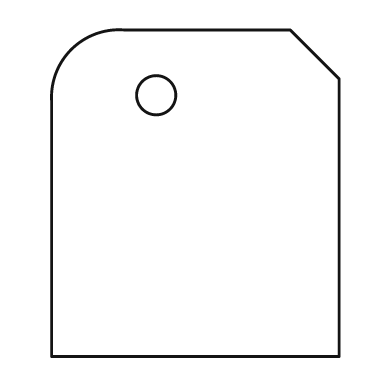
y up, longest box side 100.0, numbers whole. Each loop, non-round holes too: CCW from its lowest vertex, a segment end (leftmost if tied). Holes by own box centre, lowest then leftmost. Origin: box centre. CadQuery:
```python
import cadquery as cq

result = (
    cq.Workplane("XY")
    .moveTo(-44.0, -50.0)
    .lineTo(44.0, -50.0)
    .lineTo(44.0, 35.0)
    .lineTo(29.0, 50.0)
    .lineTo(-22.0, 50.0)
    .threePointArc((-38.0, 44.0), (-44.0, 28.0))
    .close()
    .moveTo(-12.0, 30.0)
    .circle(6.0)
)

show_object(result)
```